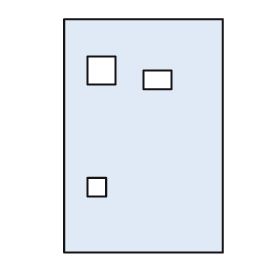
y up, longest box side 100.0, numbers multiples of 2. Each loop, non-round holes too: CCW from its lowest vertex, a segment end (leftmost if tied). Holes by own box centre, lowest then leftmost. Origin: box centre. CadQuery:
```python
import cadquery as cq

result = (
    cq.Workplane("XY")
    .moveTo(-34.0, -50.0)
    .lineTo(34.0, -50.0)
    .lineTo(34.0, 50.0)
    .lineTo(-34.0, 50.0)
    .close()
    .moveTo(-24.0, -26.0)
    .lineTo(-16.0, -26.0)
    .lineTo(-16.0, -18.0)
    .lineTo(-24.0, -18.0)
    .close()
    .moveTo(0.0, 20.0)
    .lineTo(12.0, 20.0)
    .lineTo(12.0, 28.0)
    .lineTo(0.0, 28.0)
    .close()
    .moveTo(-24.0, 22.0)
    .lineTo(-12.0, 22.0)
    .lineTo(-12.0, 34.0)
    .lineTo(-24.0, 34.0)
    .close()
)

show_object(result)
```